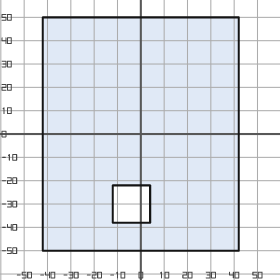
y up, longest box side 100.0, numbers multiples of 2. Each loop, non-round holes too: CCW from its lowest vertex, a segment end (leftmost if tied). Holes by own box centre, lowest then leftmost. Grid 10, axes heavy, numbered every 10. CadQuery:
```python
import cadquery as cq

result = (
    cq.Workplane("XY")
    .moveTo(-42.0, -50.0)
    .lineTo(42.0, -50.0)
    .lineTo(42.0, 50.0)
    .lineTo(-42.0, 50.0)
    .close()
    .moveTo(-12.0, -38.0)
    .lineTo(4.0, -38.0)
    .lineTo(4.0, -22.0)
    .lineTo(-12.0, -22.0)
    .close()
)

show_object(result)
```